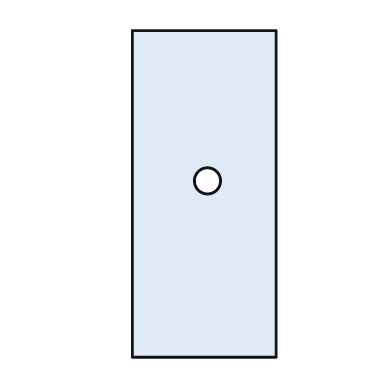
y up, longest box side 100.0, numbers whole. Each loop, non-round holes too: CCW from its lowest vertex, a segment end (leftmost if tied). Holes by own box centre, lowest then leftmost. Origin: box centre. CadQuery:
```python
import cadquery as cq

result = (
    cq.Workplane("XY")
    .moveTo(-22.0, -50.0)
    .lineTo(22.0, -50.0)
    .lineTo(22.0, 50.0)
    .lineTo(-22.0, 50.0)
    .close()
    .moveTo(1.0, 4.0)
    .circle(4.0)
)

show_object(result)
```